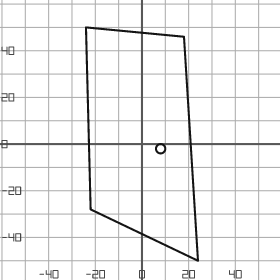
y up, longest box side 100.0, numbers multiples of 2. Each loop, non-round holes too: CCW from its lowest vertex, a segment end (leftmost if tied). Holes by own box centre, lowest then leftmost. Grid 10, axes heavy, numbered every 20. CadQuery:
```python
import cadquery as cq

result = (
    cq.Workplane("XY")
    .moveTo(24.0, -50.0)
    .lineTo(18.0, 46.0)
    .lineTo(-24.0, 50.0)
    .lineTo(-22.0, -28.0)
    .close()
    .moveTo(8.0, -2.0)
    .circle(2.0)
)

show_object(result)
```